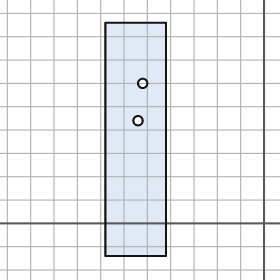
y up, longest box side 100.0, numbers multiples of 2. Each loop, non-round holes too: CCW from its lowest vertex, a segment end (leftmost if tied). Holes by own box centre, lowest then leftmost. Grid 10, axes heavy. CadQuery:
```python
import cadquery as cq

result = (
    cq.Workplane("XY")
    .moveTo(-68.0, -14.0)
    .lineTo(-42.0, -14.0)
    .lineTo(-42.0, 86.0)
    .lineTo(-68.0, 86.0)
    .close()
    .moveTo(-54.0, 44.0)
    .circle(2.0)
    .moveTo(-52.0, 60.0)
    .circle(2.0)
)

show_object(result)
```